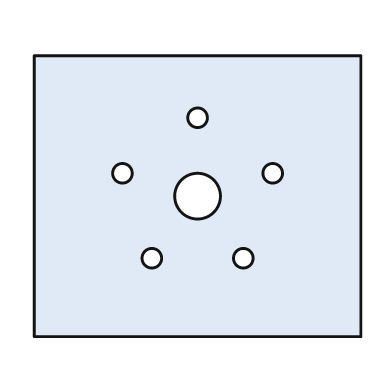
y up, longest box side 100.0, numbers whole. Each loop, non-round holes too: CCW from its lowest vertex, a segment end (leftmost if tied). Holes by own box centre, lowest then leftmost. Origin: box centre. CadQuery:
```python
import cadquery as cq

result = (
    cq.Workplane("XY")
    .moveTo(-50.0, -43.0)
    .lineTo(50.0, -43.0)
    .lineTo(50.0, 43.0)
    .lineTo(-50.0, 43.0)
    .close()
    .moveTo(-14.0, -19.0)
    .circle(3.0)
    .moveTo(14.0, -19.0)
    .circle(3.0)
    .moveTo(0.0, 0.0)
    .circle(7.0)
    .moveTo(-23.0, 7.0)
    .circle(3.0)
    .moveTo(23.0, 7.0)
    .circle(3.0)
    .moveTo(0.0, 24.0)
    .circle(3.0)
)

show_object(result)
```